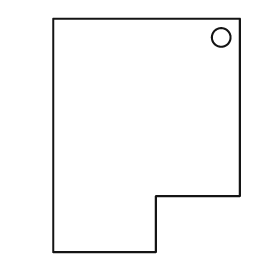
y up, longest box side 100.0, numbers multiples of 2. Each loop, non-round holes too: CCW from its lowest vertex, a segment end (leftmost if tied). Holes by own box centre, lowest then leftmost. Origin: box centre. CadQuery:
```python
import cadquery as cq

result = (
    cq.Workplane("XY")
    .moveTo(-40.0, -50.0)
    .lineTo(4.0, -50.0)
    .lineTo(4.0, -26.0)
    .lineTo(40.0, -26.0)
    .lineTo(40.0, 50.0)
    .lineTo(-40.0, 50.0)
    .close()
    .moveTo(32.0, 42.0)
    .circle(4.0)
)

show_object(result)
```